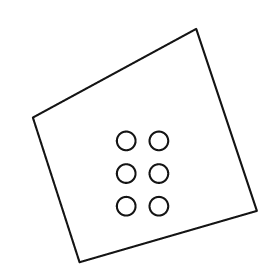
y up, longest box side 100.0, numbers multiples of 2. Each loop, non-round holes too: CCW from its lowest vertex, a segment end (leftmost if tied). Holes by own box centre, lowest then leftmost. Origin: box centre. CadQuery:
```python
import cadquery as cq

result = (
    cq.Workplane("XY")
    .moveTo(-28.0, -50.0)
    .lineTo(48.0, -28.0)
    .lineTo(22.0, 50.0)
    .lineTo(-48.0, 12.0)
    .close()
    .moveTo(-8.0, -26.0)
    .circle(4.0)
    .moveTo(6.0, -26.0)
    .circle(4.0)
    .moveTo(-8.0, -12.0)
    .circle(4.0)
    .moveTo(6.0, -12.0)
    .circle(4.0)
    .moveTo(-8.0, 2.0)
    .circle(4.0)
    .moveTo(6.0, 2.0)
    .circle(4.0)
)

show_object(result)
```